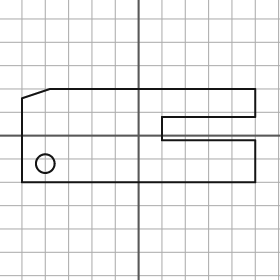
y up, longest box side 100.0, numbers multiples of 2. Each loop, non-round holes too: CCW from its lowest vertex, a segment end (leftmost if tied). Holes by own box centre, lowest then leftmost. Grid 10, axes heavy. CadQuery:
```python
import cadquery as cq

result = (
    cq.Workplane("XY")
    .moveTo(-50.0, -20.0)
    .lineTo(50.0, -20.0)
    .lineTo(50.0, -2.0)
    .lineTo(10.0, -2.0)
    .lineTo(10.0, 8.0)
    .lineTo(50.0, 8.0)
    .lineTo(50.0, 20.0)
    .lineTo(-38.0, 20.0)
    .lineTo(-50.0, 16.0)
    .close()
    .moveTo(-40.0, -12.0)
    .circle(4.0)
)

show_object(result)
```